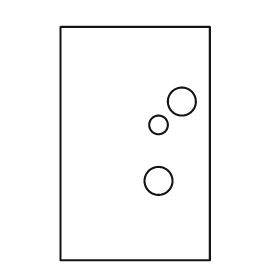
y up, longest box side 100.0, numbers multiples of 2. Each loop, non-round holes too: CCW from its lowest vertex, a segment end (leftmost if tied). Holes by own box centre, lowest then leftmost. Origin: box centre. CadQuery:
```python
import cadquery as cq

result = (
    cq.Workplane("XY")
    .moveTo(-32.0, -50.0)
    .lineTo(32.0, -50.0)
    .lineTo(32.0, 50.0)
    .lineTo(-32.0, 50.0)
    .close()
    .moveTo(10.0, -16.0)
    .circle(6.0)
    .moveTo(10.0, 8.0)
    .circle(4.0)
    .moveTo(20.0, 18.0)
    .circle(6.0)
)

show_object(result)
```